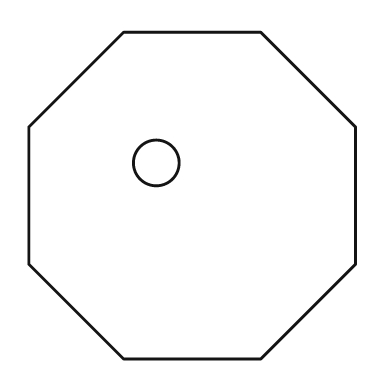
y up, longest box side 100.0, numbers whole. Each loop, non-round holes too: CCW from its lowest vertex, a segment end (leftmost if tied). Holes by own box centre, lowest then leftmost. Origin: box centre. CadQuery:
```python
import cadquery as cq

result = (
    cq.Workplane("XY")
    .moveTo(-21.0, -50.0)
    .lineTo(21.0, -50.0)
    .lineTo(50.0, -21.0)
    .lineTo(50.0, 21.0)
    .lineTo(21.0, 50.0)
    .lineTo(-21.0, 50.0)
    .lineTo(-50.0, 21.0)
    .lineTo(-50.0, -21.0)
    .close()
    .moveTo(-11.0, 10.0)
    .circle(7.0)
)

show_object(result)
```